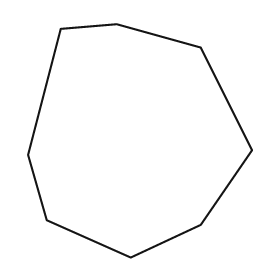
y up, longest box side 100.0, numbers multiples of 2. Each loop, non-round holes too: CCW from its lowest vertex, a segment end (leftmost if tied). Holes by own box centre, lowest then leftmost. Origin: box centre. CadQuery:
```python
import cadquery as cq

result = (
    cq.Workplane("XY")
    .moveTo(-4.0, -50.0)
    .lineTo(26.0, -36.0)
    .lineTo(48.0, -4.0)
    .lineTo(26.0, 40.0)
    .lineTo(-10.0, 50.0)
    .lineTo(-34.0, 48.0)
    .lineTo(-48.0, -6.0)
    .lineTo(-40.0, -34.0)
    .close()
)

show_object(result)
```